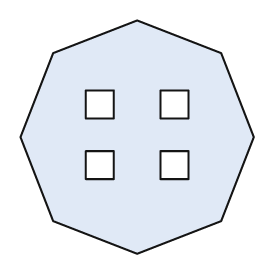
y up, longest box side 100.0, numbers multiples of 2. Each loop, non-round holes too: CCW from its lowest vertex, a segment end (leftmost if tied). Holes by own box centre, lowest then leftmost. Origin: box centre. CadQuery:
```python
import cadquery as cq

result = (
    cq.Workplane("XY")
    .moveTo(0.0, -50.0)
    .lineTo(36.0, -36.0)
    .lineTo(50.0, 0.0)
    .lineTo(36.0, 36.0)
    .lineTo(0.0, 50.0)
    .lineTo(-36.0, 36.0)
    .lineTo(-50.0, 0.0)
    .lineTo(-36.0, -36.0)
    .close()
    .moveTo(-22.0, -18.0)
    .lineTo(-10.0, -18.0)
    .lineTo(-10.0, -6.0)
    .lineTo(-22.0, -6.0)
    .close()
    .moveTo(10.0, -18.0)
    .lineTo(22.0, -18.0)
    .lineTo(22.0, -6.0)
    .lineTo(10.0, -6.0)
    .close()
    .moveTo(-22.0, 8.0)
    .lineTo(-10.0, 8.0)
    .lineTo(-10.0, 20.0)
    .lineTo(-22.0, 20.0)
    .close()
    .moveTo(10.0, 8.0)
    .lineTo(22.0, 8.0)
    .lineTo(22.0, 20.0)
    .lineTo(10.0, 20.0)
    .close()
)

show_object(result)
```